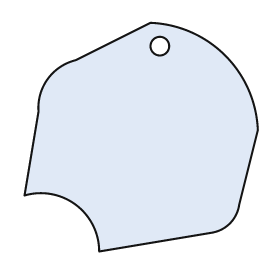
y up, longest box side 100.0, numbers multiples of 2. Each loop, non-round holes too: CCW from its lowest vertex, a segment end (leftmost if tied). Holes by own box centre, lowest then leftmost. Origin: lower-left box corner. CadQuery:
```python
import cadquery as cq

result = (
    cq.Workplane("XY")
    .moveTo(32.0, 0.0)
    .lineTo(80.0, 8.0)
    .threePointArc((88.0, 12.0), (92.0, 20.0))
    .lineTo(100.0, 52.0)
    .threePointArc((86.0, 84.0), (54.0, 98.0))
    .lineTo(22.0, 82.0)
    .threePointArc((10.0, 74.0), (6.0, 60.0))
    .lineTo(0.0, 24.0)
    .threePointArc((22.0, 20.0), (32.0, 0.0))
    .close()
    .moveTo(58.0, 88.0)
    .circle(4.0)
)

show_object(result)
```